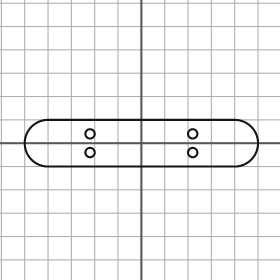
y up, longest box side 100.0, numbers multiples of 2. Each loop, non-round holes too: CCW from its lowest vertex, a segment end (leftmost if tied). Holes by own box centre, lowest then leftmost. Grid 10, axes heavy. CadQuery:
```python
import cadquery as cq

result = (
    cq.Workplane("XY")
    .moveTo(-40.0, -10.0)
    .lineTo(40.0, -10.0)
    .threePointArc((50.0, 0.0), (40.0, 10.0))
    .lineTo(-40.0, 10.0)
    .threePointArc((-50.0, 0.0), (-40.0, -10.0))
    .close()
    .moveTo(-22.0, -4.0)
    .circle(2.0)
    .moveTo(22.0, -4.0)
    .circle(2.0)
    .moveTo(-22.0, 4.0)
    .circle(2.0)
    .moveTo(22.0, 4.0)
    .circle(2.0)
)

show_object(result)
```